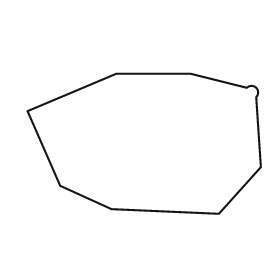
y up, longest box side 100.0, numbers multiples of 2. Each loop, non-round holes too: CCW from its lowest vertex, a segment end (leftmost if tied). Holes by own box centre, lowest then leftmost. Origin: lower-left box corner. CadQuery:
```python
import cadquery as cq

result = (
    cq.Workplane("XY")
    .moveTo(82.0, 0.0)
    .lineTo(100.0, 20.0)
    .lineTo(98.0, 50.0)
    .threePointArc((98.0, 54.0), (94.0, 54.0))
    .lineTo(70.0, 60.0)
    .lineTo(38.0, 60.0)
    .lineTo(0.0, 44.0)
    .lineTo(14.0, 12.0)
    .lineTo(36.0, 2.0)
    .close()
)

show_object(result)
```